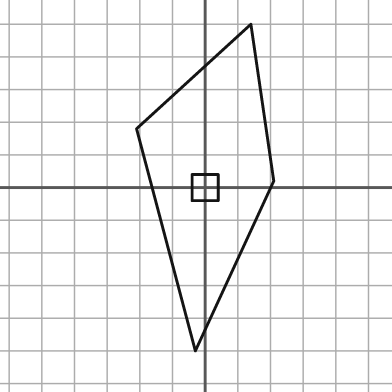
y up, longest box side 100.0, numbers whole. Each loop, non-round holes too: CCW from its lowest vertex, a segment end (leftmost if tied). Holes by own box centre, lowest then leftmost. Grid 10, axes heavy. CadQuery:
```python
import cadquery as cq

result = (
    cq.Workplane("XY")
    .moveTo(-3.0, -50.0)
    .lineTo(21.0, 2.0)
    .lineTo(14.0, 50.0)
    .lineTo(-21.0, 18.0)
    .close()
    .moveTo(-4.0, -4.0)
    .lineTo(4.0, -4.0)
    .lineTo(4.0, 4.0)
    .lineTo(-4.0, 4.0)
    .close()
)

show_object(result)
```